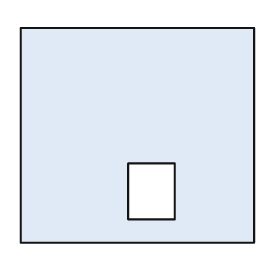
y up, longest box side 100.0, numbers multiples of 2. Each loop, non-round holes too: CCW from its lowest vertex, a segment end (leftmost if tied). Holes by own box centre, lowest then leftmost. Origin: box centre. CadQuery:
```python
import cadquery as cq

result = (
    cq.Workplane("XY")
    .moveTo(-50.0, -46.0)
    .lineTo(50.0, -46.0)
    .lineTo(50.0, 46.0)
    .lineTo(-50.0, 46.0)
    .close()
    .moveTo(-4.0, -36.0)
    .lineTo(16.0, -36.0)
    .lineTo(16.0, -12.0)
    .lineTo(-4.0, -12.0)
    .close()
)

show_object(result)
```